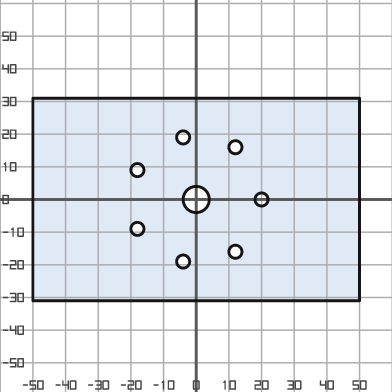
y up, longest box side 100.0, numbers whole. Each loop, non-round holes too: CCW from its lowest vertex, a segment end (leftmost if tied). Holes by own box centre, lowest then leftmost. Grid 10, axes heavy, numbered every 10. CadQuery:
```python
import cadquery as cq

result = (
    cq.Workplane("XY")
    .moveTo(-50.0, -31.0)
    .lineTo(50.0, -31.0)
    .lineTo(50.0, 31.0)
    .lineTo(-50.0, 31.0)
    .close()
    .moveTo(-4.0, -19.0)
    .circle(2.0)
    .moveTo(12.0, -16.0)
    .circle(2.0)
    .moveTo(-18.0, -9.0)
    .circle(2.0)
    .moveTo(0.0, 0.0)
    .circle(4.0)
    .moveTo(20.0, 0.0)
    .circle(2.0)
    .moveTo(-18.0, 9.0)
    .circle(2.0)
    .moveTo(12.0, 16.0)
    .circle(2.0)
    .moveTo(-4.0, 19.0)
    .circle(2.0)
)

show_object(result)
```